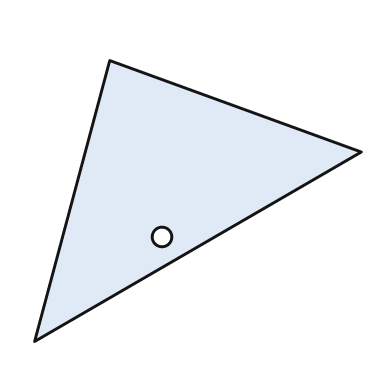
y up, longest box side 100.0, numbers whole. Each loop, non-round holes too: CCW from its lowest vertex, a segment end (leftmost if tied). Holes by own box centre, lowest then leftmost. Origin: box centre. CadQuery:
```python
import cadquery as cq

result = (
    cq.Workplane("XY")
    .moveTo(-50.0, -43.0)
    .lineTo(50.0, 15.0)
    .lineTo(-27.0, 43.0)
    .close()
    .moveTo(-11.0, -11.0)
    .circle(3.0)
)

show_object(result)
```